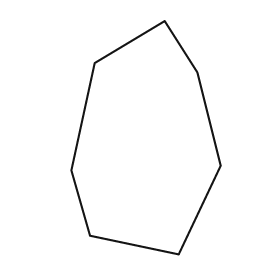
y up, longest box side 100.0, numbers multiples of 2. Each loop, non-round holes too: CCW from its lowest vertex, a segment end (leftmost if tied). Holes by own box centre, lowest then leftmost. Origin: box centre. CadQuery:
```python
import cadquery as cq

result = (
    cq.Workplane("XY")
    .moveTo(14.0, -50.0)
    .lineTo(32.0, -12.0)
    .lineTo(22.0, 28.0)
    .lineTo(8.0, 50.0)
    .lineTo(-22.0, 32.0)
    .lineTo(-32.0, -14.0)
    .lineTo(-24.0, -42.0)
    .close()
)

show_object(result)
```